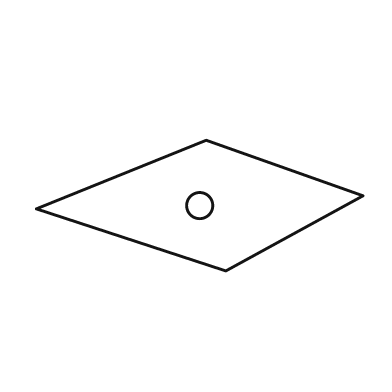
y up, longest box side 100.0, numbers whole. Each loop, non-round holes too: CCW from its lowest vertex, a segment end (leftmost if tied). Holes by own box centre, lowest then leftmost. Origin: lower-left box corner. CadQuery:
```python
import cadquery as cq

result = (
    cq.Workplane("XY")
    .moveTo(58.0, 0.0)
    .lineTo(100.0, 23.0)
    .lineTo(52.0, 40.0)
    .lineTo(0.0, 19.0)
    .close()
    .moveTo(50.0, 20.0)
    .circle(4.0)
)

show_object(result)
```